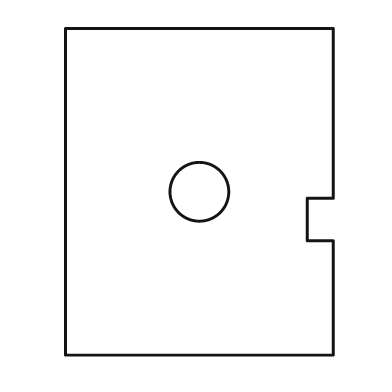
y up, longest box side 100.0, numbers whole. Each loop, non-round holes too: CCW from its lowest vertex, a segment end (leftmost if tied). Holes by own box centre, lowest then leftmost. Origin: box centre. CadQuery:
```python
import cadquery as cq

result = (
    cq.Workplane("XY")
    .moveTo(-41.0, -50.0)
    .lineTo(41.0, -50.0)
    .lineTo(41.0, -15.0)
    .lineTo(33.0, -15.0)
    .lineTo(33.0, -2.0)
    .lineTo(41.0, -2.0)
    .lineTo(41.0, 50.0)
    .lineTo(-41.0, 50.0)
    .close()
    .moveTo(0.0, 0.0)
    .circle(9.0)
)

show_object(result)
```